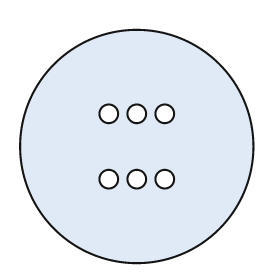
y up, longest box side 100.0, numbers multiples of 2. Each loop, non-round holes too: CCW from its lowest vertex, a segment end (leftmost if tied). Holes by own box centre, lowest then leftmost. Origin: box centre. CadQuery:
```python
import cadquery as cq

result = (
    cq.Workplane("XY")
    .moveTo(0.0, 0.0)
    .circle(50.0)
    .moveTo(-12.0, -14.0)
    .circle(4.0)
    .moveTo(0.0, -14.0)
    .circle(4.0)
    .moveTo(12.0, -14.0)
    .circle(4.0)
    .moveTo(-12.0, 14.0)
    .circle(4.0)
    .moveTo(0.0, 14.0)
    .circle(4.0)
    .moveTo(12.0, 14.0)
    .circle(4.0)
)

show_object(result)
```